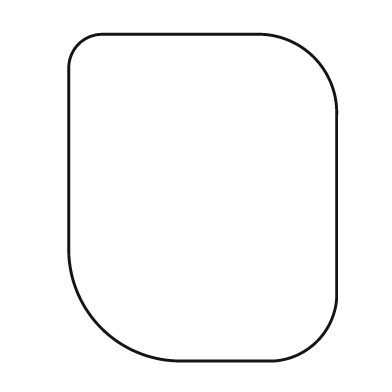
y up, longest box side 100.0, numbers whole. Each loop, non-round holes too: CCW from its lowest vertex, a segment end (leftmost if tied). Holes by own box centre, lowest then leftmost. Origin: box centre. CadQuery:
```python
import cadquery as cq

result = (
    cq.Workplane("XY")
    .moveTo(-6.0, -50.0)
    .lineTo(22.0, -50.0)
    .threePointArc((35.0, -44.0), (41.0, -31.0))
    .lineTo(41.0, 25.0)
    .threePointArc((34.0, 43.0), (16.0, 50.0))
    .lineTo(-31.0, 50.0)
    .threePointArc((-38.0, 47.0), (-41.0, 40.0))
    .lineTo(-41.0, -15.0)
    .threePointArc((-31.0, -40.0), (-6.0, -50.0))
    .close()
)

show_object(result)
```